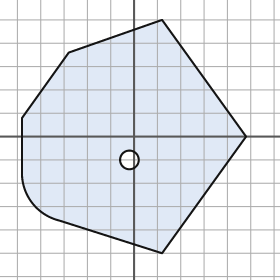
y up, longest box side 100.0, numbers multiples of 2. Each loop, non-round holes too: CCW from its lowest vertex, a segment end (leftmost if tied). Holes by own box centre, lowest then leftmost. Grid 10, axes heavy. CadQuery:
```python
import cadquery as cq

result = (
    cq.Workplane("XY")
    .moveTo(12.0, -50.0)
    .lineTo(48.0, 0.0)
    .lineTo(12.0, 50.0)
    .lineTo(-28.0, 36.0)
    .lineTo(-48.0, 8.0)
    .lineTo(-48.0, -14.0)
    .threePointArc((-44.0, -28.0), (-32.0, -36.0))
    .close()
    .moveTo(-2.0, -10.0)
    .circle(4.0)
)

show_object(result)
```